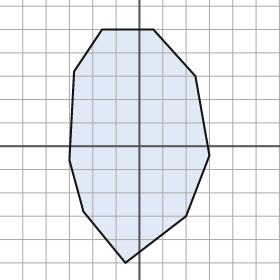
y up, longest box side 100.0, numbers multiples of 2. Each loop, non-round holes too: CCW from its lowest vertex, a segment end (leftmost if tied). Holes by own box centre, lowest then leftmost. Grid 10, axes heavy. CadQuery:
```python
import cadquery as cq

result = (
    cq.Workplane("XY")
    .moveTo(-6.0, -50.0)
    .lineTo(20.0, -30.0)
    .lineTo(30.0, -4.0)
    .lineTo(24.0, 30.0)
    .lineTo(6.0, 50.0)
    .lineTo(-16.0, 50.0)
    .lineTo(-28.0, 32.0)
    .lineTo(-30.0, -6.0)
    .lineTo(-24.0, -28.0)
    .close()
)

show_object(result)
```